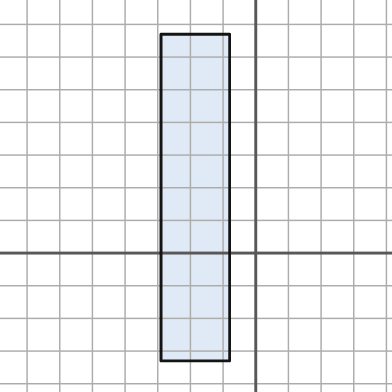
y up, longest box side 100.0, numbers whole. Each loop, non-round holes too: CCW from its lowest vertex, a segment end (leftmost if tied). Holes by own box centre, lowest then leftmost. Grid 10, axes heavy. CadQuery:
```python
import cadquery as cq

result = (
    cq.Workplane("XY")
    .moveTo(-29.0, -33.0)
    .lineTo(-8.0, -33.0)
    .lineTo(-8.0, 67.0)
    .lineTo(-29.0, 67.0)
    .close()
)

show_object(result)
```